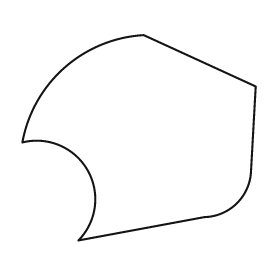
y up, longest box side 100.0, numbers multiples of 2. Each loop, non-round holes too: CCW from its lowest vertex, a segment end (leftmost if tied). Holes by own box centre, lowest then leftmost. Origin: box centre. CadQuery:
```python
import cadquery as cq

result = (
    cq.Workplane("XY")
    .moveTo(-26.0, -44.0)
    .lineTo(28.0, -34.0)
    .threePointArc((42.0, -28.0), (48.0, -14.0))
    .lineTo(50.0, 22.0)
    .lineTo(2.0, 44.0)
    .threePointArc((-32.0, 30.0), (-50.0, -2.0))
    .threePointArc((-22.0, -14.0), (-26.0, -44.0))
    .close()
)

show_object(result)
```